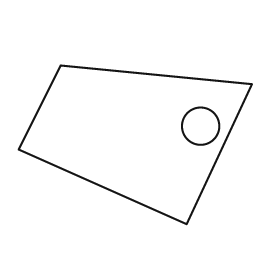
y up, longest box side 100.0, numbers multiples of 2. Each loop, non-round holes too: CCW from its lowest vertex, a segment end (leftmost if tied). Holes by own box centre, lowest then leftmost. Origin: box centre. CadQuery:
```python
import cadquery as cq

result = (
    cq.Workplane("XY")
    .moveTo(22.0, -34.0)
    .lineTo(50.0, 26.0)
    .lineTo(-32.0, 34.0)
    .lineTo(-50.0, -2.0)
    .close()
    .moveTo(28.0, 8.0)
    .circle(8.0)
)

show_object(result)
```